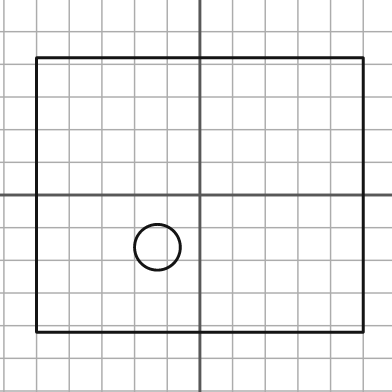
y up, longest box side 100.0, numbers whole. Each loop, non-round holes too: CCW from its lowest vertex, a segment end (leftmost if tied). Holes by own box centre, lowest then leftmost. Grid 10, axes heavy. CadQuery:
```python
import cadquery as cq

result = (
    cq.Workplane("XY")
    .moveTo(-50.0, -42.0)
    .lineTo(50.0, -42.0)
    .lineTo(50.0, 42.0)
    .lineTo(-50.0, 42.0)
    .close()
    .moveTo(-13.0, -16.0)
    .circle(7.0)
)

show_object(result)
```